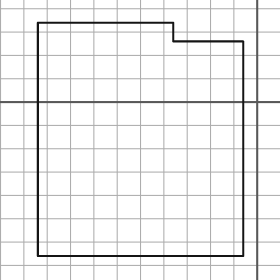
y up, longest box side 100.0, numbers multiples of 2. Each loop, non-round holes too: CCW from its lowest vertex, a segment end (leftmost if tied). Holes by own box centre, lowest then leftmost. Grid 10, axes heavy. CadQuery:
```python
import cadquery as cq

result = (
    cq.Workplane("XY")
    .moveTo(-94.0, -66.0)
    .lineTo(-6.0, -66.0)
    .lineTo(-6.0, 26.0)
    .lineTo(-36.0, 26.0)
    .lineTo(-36.0, 34.0)
    .lineTo(-94.0, 34.0)
    .close()
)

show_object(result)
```